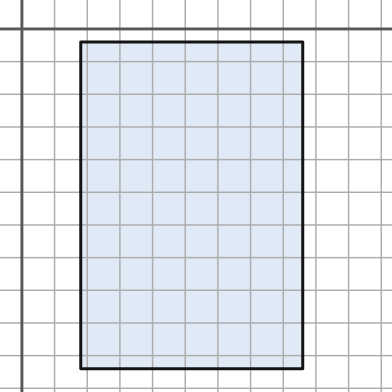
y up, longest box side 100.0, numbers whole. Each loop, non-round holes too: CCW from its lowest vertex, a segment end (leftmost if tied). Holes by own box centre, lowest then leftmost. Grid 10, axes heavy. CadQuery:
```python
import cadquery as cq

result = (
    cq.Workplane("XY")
    .moveTo(18.0, -104.0)
    .lineTo(86.0, -104.0)
    .lineTo(86.0, -4.0)
    .lineTo(18.0, -4.0)
    .close()
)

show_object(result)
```